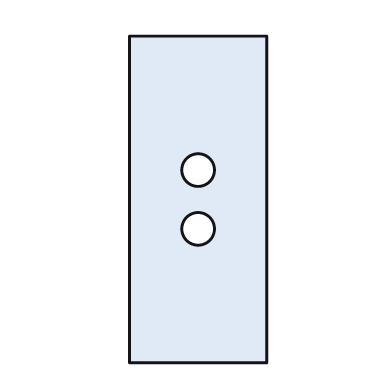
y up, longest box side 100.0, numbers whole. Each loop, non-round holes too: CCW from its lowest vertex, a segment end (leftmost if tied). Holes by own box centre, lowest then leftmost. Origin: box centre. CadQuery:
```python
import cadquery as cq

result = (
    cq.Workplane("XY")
    .moveTo(-21.0, -50.0)
    .lineTo(21.0, -50.0)
    .lineTo(21.0, 50.0)
    .lineTo(-21.0, 50.0)
    .close()
    .moveTo(0.0, -9.0)
    .circle(5.0)
    .moveTo(0.0, 9.0)
    .circle(5.0)
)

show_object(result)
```